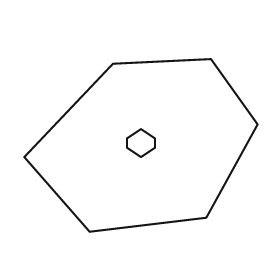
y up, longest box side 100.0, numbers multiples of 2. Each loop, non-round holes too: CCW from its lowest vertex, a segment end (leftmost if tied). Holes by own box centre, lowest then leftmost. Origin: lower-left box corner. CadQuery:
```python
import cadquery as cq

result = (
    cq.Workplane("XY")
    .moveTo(28.0, 0.0)
    .lineTo(78.0, 6.0)
    .lineTo(100.0, 46.0)
    .lineTo(80.0, 74.0)
    .lineTo(38.0, 72.0)
    .lineTo(0.0, 32.0)
    .close()
    .moveTo(50.0, 32.0)
    .lineTo(56.0, 36.0)
    .lineTo(56.0, 40.0)
    .lineTo(50.0, 44.0)
    .lineTo(44.0, 40.0)
    .lineTo(44.0, 36.0)
    .close()
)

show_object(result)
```